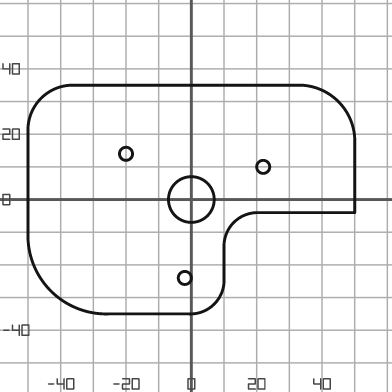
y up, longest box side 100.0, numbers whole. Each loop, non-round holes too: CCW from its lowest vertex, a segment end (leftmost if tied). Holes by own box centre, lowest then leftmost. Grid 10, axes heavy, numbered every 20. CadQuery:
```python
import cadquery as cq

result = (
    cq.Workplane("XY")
    .moveTo(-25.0, -35.0)
    .lineTo(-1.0, -35.0)
    .threePointArc((7.0, -32.0), (10.0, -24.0))
    .lineTo(10.0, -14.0)
    .threePointArc((13.0, -7.0), (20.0, -4.0))
    .lineTo(50.0, -4.0)
    .lineTo(50.0, 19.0)
    .threePointArc((45.0, 30.0), (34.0, 35.0))
    .lineTo(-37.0, 35.0)
    .threePointArc((-46.0, 31.0), (-50.0, 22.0))
    .lineTo(-50.0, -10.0)
    .threePointArc((-43.0, -28.0), (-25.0, -35.0))
    .close()
    .moveTo(-2.0, -24.0)
    .circle(2.0)
    .moveTo(0.0, 0.0)
    .circle(7.0)
    .moveTo(22.0, 10.0)
    .circle(2.0)
    .moveTo(-20.0, 14.0)
    .circle(2.0)
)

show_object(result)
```